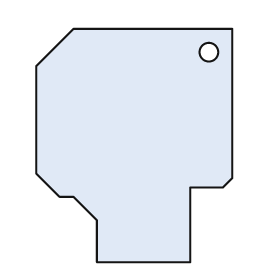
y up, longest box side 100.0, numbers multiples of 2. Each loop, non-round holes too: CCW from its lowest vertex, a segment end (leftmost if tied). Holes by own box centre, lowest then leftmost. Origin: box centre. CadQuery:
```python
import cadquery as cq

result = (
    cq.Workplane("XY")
    .moveTo(-16.0, -50.0)
    .lineTo(24.0, -50.0)
    .lineTo(24.0, -18.0)
    .lineTo(38.0, -18.0)
    .lineTo(42.0, -14.0)
    .lineTo(42.0, 50.0)
    .lineTo(-26.0, 50.0)
    .lineTo(-42.0, 34.0)
    .lineTo(-42.0, -12.0)
    .lineTo(-32.0, -22.0)
    .lineTo(-26.0, -22.0)
    .lineTo(-16.0, -32.0)
    .close()
    .moveTo(32.0, 40.0)
    .circle(4.0)
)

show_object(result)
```